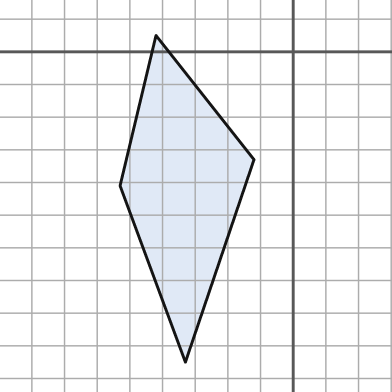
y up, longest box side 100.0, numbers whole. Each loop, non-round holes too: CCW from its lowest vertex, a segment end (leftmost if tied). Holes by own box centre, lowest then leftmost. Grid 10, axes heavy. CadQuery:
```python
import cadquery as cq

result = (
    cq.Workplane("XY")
    .moveTo(-33.0, -95.0)
    .lineTo(-12.0, -33.0)
    .lineTo(-42.0, 5.0)
    .lineTo(-53.0, -41.0)
    .close()
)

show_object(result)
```